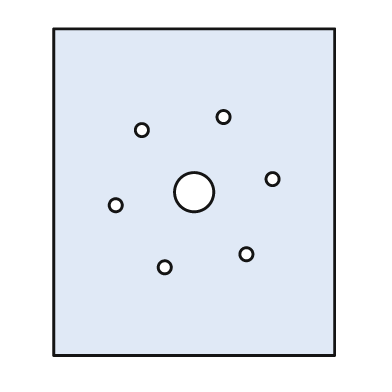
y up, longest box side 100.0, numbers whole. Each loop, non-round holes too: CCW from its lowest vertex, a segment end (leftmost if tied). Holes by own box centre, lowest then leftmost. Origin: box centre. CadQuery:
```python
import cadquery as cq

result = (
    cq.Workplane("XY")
    .moveTo(-43.0, -50.0)
    .lineTo(43.0, -50.0)
    .lineTo(43.0, 50.0)
    .lineTo(-43.0, 50.0)
    .close()
    .moveTo(-9.0, -23.0)
    .circle(2.0)
    .moveTo(16.0, -19.0)
    .circle(2.0)
    .moveTo(-24.0, -4.0)
    .circle(2.0)
    .moveTo(0.0, 0.0)
    .circle(6.0)
    .moveTo(24.0, 4.0)
    .circle(2.0)
    .moveTo(-16.0, 19.0)
    .circle(2.0)
    .moveTo(9.0, 23.0)
    .circle(2.0)
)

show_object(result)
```